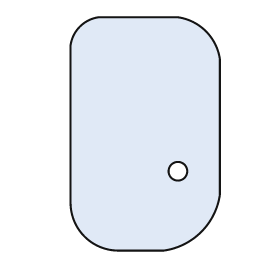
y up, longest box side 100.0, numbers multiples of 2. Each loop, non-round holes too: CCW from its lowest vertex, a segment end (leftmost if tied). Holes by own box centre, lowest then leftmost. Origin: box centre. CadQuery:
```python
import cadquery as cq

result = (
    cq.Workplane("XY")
    .moveTo(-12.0, -50.0)
    .lineTo(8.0, -50.0)
    .threePointArc((24.0, -42.0), (32.0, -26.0))
    .lineTo(32.0, 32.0)
    .threePointArc((26.0, 44.0), (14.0, 50.0))
    .lineTo(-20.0, 50.0)
    .threePointArc((-28.0, 46.0), (-32.0, 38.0))
    .lineTo(-32.0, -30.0)
    .threePointArc((-26.0, -44.0), (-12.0, -50.0))
    .close()
    .moveTo(14.0, -16.0)
    .circle(4.0)
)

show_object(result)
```